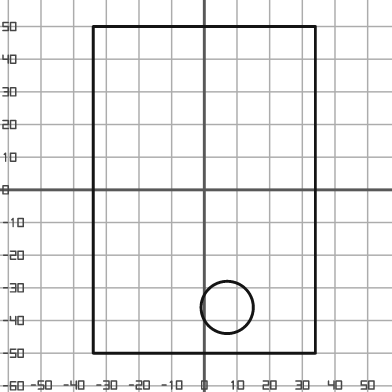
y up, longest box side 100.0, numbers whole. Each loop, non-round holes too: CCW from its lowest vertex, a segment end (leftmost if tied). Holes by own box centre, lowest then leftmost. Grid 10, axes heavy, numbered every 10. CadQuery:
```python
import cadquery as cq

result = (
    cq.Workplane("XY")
    .moveTo(-34.0, -50.0)
    .lineTo(34.0, -50.0)
    .lineTo(34.0, 50.0)
    .lineTo(-34.0, 50.0)
    .close()
    .moveTo(7.0, -36.0)
    .circle(8.0)
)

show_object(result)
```